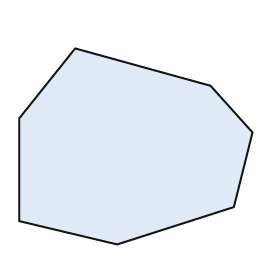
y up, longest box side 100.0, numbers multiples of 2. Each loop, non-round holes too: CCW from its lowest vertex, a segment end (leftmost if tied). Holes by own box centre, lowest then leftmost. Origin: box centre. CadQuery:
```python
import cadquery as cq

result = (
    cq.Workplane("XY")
    .moveTo(-8.0, -42.0)
    .lineTo(42.0, -26.0)
    .lineTo(50.0, 6.0)
    .lineTo(32.0, 26.0)
    .lineTo(-26.0, 42.0)
    .lineTo(-50.0, 12.0)
    .lineTo(-50.0, -32.0)
    .close()
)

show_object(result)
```